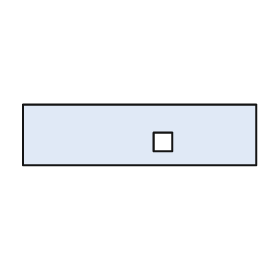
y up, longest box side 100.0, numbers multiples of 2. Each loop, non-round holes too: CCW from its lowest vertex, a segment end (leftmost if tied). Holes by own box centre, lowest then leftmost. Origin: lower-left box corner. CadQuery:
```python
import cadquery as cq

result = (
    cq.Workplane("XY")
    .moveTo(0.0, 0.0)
    .lineTo(100.0, 0.0)
    .lineTo(100.0, 26.0)
    .lineTo(0.0, 26.0)
    .close()
    .moveTo(56.0, 6.0)
    .lineTo(64.0, 6.0)
    .lineTo(64.0, 14.0)
    .lineTo(56.0, 14.0)
    .close()
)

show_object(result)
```